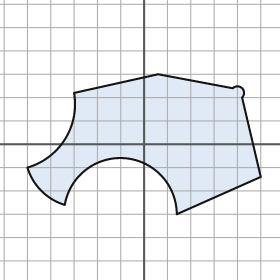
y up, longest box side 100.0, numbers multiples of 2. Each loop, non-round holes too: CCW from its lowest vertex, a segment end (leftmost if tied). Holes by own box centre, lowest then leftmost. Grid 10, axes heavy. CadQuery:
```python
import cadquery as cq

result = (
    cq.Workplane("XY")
    .moveTo(14.0, -30.0)
    .lineTo(50.0, -14.0)
    .lineTo(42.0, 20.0)
    .threePointArc((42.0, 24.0), (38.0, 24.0))
    .lineTo(6.0, 30.0)
    .lineTo(-30.0, 22.0)
    .threePointArc((-34.0, 2.0), (-50.0, -10.0))
    .threePointArc((-44.0, -20.0), (-34.0, -26.0))
    .threePointArc((-8.0, -6.0), (14.0, -30.0))
    .close()
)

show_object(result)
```